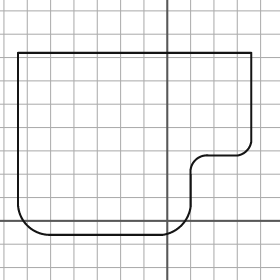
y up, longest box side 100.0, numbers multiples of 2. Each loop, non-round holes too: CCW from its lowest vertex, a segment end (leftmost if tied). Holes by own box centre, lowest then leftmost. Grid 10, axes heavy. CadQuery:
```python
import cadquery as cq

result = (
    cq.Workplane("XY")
    .moveTo(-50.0, -6.0)
    .lineTo(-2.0, -6.0)
    .threePointArc((6.0, -2.0), (10.0, 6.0))
    .lineTo(10.0, 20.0)
    .threePointArc((12.0, 26.0), (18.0, 28.0))
    .lineTo(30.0, 28.0)
    .threePointArc((34.0, 30.0), (36.0, 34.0))
    .lineTo(36.0, 72.0)
    .lineTo(-64.0, 72.0)
    .lineTo(-64.0, 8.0)
    .threePointArc((-60.0, -2.0), (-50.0, -6.0))
    .close()
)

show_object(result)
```